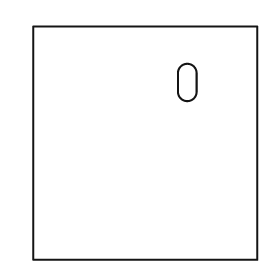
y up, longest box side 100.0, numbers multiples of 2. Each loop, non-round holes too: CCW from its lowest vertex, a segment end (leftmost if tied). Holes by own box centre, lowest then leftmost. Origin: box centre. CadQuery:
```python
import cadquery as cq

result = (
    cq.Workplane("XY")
    .moveTo(-48.0, -50.0)
    .lineTo(48.0, -50.0)
    .lineTo(48.0, 50.0)
    .lineTo(-48.0, 50.0)
    .close()
    .moveTo(14.0, 22.0)
    .threePointArc((18.0, 18.0), (22.0, 22.0))
    .lineTo(22.0, 30.0)
    .threePointArc((18.0, 34.0), (14.0, 30.0))
    .close()
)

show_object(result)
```